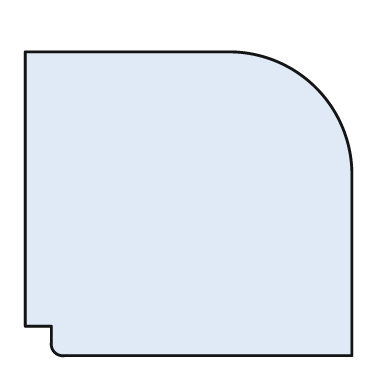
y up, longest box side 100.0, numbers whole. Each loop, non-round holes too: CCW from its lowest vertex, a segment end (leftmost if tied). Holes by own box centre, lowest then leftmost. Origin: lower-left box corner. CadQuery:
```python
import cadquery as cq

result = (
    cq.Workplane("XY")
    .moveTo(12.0, 0.0)
    .lineTo(100.0, 0.0)
    .lineTo(100.0, 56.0)
    .threePointArc((89.0, 82.0), (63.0, 93.0))
    .lineTo(0.0, 93.0)
    .lineTo(0.0, 9.0)
    .lineTo(8.0, 9.0)
    .lineTo(8.0, 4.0)
    .threePointArc((9.0, 1.0), (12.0, 0.0))
    .close()
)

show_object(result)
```